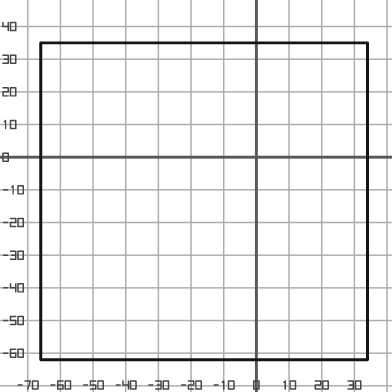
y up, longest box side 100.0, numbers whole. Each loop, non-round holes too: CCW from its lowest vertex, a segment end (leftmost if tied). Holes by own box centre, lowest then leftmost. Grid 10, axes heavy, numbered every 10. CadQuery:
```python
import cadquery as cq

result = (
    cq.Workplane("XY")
    .moveTo(-66.0, -62.0)
    .lineTo(34.0, -62.0)
    .lineTo(34.0, 35.0)
    .lineTo(-66.0, 35.0)
    .close()
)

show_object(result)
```